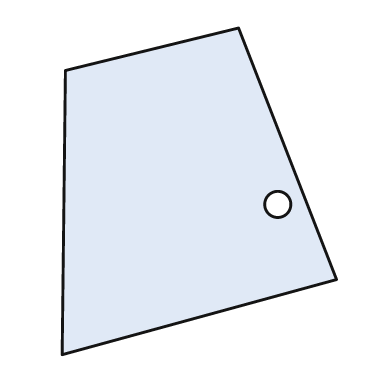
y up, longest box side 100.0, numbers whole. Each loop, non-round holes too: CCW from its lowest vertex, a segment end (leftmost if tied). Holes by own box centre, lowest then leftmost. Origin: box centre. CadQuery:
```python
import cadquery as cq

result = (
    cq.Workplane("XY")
    .moveTo(-42.0, -50.0)
    .lineTo(42.0, -27.0)
    .lineTo(12.0, 50.0)
    .lineTo(-41.0, 37.0)
    .close()
    .moveTo(24.0, -4.0)
    .circle(4.0)
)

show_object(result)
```